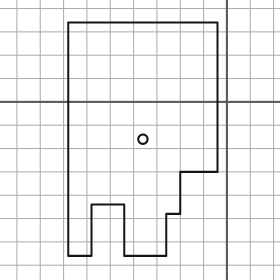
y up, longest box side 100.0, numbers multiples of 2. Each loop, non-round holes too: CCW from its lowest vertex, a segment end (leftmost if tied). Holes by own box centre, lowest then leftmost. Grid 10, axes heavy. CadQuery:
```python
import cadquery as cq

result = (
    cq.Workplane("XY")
    .moveTo(-68.0, -66.0)
    .lineTo(-58.0, -66.0)
    .lineTo(-58.0, -44.0)
    .lineTo(-44.0, -44.0)
    .lineTo(-44.0, -66.0)
    .lineTo(-26.0, -66.0)
    .lineTo(-26.0, -48.0)
    .lineTo(-20.0, -48.0)
    .lineTo(-20.0, -30.0)
    .lineTo(-4.0, -30.0)
    .lineTo(-4.0, 34.0)
    .lineTo(-68.0, 34.0)
    .close()
    .moveTo(-36.0, -16.0)
    .circle(2.0)
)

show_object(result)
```